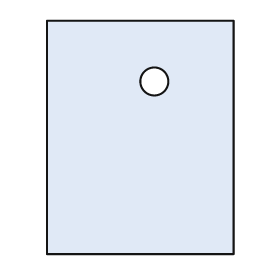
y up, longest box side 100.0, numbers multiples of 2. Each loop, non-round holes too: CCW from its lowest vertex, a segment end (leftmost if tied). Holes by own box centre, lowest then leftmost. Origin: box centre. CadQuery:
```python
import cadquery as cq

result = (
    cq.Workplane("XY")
    .moveTo(-40.0, -50.0)
    .lineTo(40.0, -50.0)
    .lineTo(40.0, 50.0)
    .lineTo(-40.0, 50.0)
    .close()
    .moveTo(6.0, 24.0)
    .circle(6.0)
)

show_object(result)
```